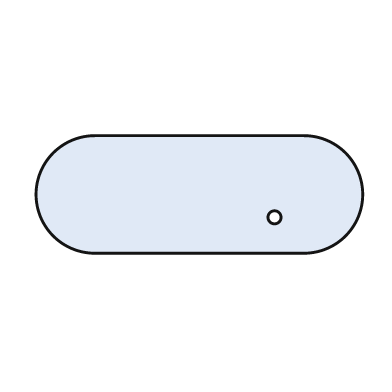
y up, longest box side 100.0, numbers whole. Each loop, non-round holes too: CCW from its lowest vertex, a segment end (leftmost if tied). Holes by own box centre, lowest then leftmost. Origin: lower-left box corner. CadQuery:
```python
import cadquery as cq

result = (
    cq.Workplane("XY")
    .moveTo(18.0, 0.0)
    .lineTo(82.0, 0.0)
    .threePointArc((100.0, 18.0), (82.0, 36.0))
    .lineTo(18.0, 36.0)
    .threePointArc((0.0, 18.0), (18.0, 0.0))
    .close()
    .moveTo(73.0, 11.0)
    .circle(2.0)
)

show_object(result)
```